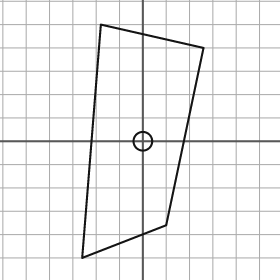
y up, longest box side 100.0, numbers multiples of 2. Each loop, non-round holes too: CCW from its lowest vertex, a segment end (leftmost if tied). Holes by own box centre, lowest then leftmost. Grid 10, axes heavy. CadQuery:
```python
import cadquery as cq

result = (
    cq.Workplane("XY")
    .moveTo(-26.0, -50.0)
    .lineTo(10.0, -36.0)
    .lineTo(26.0, 40.0)
    .lineTo(-18.0, 50.0)
    .close()
    .moveTo(0.0, 0.0)
    .circle(4.0)
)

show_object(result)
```